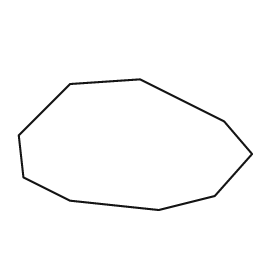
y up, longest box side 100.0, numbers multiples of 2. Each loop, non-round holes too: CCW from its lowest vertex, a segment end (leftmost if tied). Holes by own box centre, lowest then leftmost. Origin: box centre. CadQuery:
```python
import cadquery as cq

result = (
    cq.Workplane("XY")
    .moveTo(10.0, -28.0)
    .lineTo(34.0, -22.0)
    .lineTo(50.0, -4.0)
    .lineTo(38.0, 10.0)
    .lineTo(2.0, 28.0)
    .lineTo(-28.0, 26.0)
    .lineTo(-50.0, 4.0)
    .lineTo(-48.0, -14.0)
    .lineTo(-28.0, -24.0)
    .close()
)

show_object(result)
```